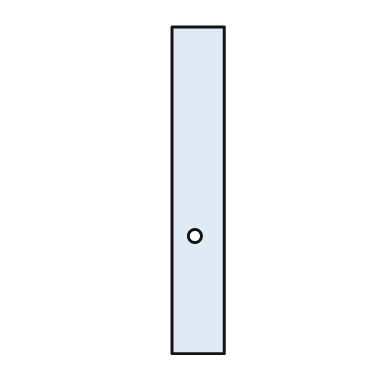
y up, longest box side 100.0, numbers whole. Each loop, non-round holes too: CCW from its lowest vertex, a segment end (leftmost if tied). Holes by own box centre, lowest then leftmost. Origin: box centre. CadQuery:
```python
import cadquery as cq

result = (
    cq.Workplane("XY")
    .moveTo(-8.0, -50.0)
    .lineTo(8.0, -50.0)
    .lineTo(8.0, 50.0)
    .lineTo(-8.0, 50.0)
    .close()
    .moveTo(-1.0, -14.0)
    .circle(2.0)
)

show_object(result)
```